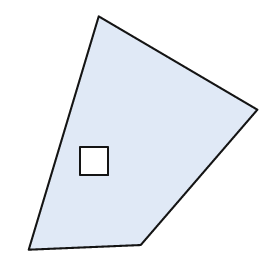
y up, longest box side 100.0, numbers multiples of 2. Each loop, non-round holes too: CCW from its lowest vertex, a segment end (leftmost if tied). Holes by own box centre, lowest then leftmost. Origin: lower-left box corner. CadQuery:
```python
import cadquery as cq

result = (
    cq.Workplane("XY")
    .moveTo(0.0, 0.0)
    .lineTo(48.0, 2.0)
    .lineTo(98.0, 60.0)
    .lineTo(30.0, 100.0)
    .close()
    .moveTo(22.0, 32.0)
    .lineTo(34.0, 32.0)
    .lineTo(34.0, 44.0)
    .lineTo(22.0, 44.0)
    .close()
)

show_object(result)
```